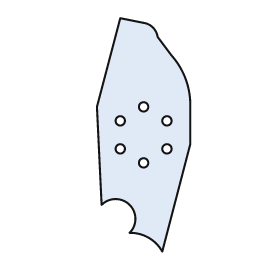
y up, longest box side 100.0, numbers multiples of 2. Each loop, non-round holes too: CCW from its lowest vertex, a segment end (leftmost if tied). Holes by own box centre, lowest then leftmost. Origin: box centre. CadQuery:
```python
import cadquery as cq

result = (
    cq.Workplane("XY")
    .moveTo(8.0, -50.0)
    .lineTo(20.0, -4.0)
    .lineTo(20.0, 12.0)
    .threePointArc((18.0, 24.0), (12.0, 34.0))
    .lineTo(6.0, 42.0)
    .threePointArc((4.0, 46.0), (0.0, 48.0))
    .lineTo(-10.0, 50.0)
    .lineTo(-20.0, 12.0)
    .lineTo(-18.0, -30.0)
    .threePointArc((-6.0, -30.0), (-6.0, -42.0))
    .threePointArc((2.0, -44.0), (8.0, -50.0))
    .close()
    .moveTo(0.0, -12.0)
    .circle(2.0)
    .moveTo(-10.0, -6.0)
    .circle(2.0)
    .moveTo(10.0, -6.0)
    .circle(2.0)
    .moveTo(-10.0, 6.0)
    .circle(2.0)
    .moveTo(10.0, 6.0)
    .circle(2.0)
    .moveTo(0.0, 12.0)
    .circle(2.0)
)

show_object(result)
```